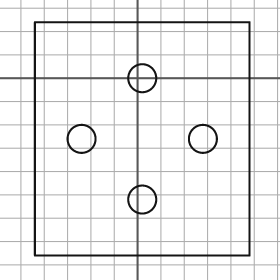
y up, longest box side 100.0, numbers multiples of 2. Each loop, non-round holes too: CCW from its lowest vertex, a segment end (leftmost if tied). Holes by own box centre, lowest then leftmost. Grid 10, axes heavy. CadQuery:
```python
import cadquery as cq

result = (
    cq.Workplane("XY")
    .moveTo(-44.0, -76.0)
    .lineTo(48.0, -76.0)
    .lineTo(48.0, 24.0)
    .lineTo(-44.0, 24.0)
    .close()
    .moveTo(2.0, -52.0)
    .circle(6.0)
    .moveTo(-24.0, -26.0)
    .circle(6.0)
    .moveTo(28.0, -26.0)
    .circle(6.0)
    .moveTo(2.0, 0.0)
    .circle(6.0)
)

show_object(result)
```